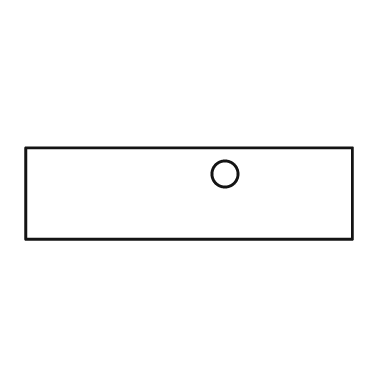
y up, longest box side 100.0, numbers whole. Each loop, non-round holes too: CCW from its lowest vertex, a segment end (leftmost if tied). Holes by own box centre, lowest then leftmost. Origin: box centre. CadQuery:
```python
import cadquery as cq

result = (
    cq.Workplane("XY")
    .moveTo(-50.0, -14.0)
    .lineTo(50.0, -14.0)
    .lineTo(50.0, 14.0)
    .lineTo(-50.0, 14.0)
    .close()
    .moveTo(11.0, 6.0)
    .circle(4.0)
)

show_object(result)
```